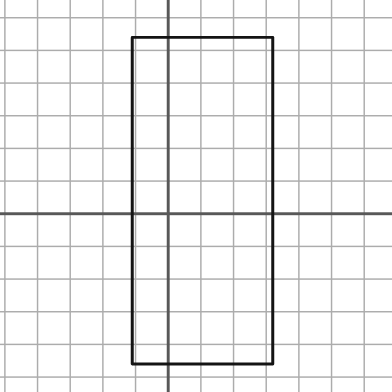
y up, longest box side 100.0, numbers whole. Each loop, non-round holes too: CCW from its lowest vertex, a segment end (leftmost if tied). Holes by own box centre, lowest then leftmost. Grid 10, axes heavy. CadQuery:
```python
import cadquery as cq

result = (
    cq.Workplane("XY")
    .moveTo(-11.0, -46.0)
    .lineTo(32.0, -46.0)
    .lineTo(32.0, 54.0)
    .lineTo(-11.0, 54.0)
    .close()
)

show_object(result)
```